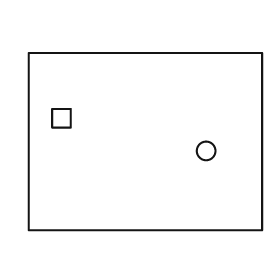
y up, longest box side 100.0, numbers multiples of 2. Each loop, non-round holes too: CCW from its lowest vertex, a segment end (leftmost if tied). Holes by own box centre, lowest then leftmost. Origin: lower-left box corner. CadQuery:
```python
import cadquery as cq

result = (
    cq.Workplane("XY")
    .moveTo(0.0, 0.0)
    .lineTo(100.0, 0.0)
    .lineTo(100.0, 76.0)
    .lineTo(0.0, 76.0)
    .close()
    .moveTo(76.0, 34.0)
    .circle(4.0)
    .moveTo(10.0, 44.0)
    .lineTo(18.0, 44.0)
    .lineTo(18.0, 52.0)
    .lineTo(10.0, 52.0)
    .close()
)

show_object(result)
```